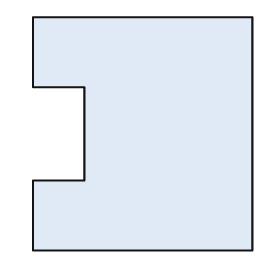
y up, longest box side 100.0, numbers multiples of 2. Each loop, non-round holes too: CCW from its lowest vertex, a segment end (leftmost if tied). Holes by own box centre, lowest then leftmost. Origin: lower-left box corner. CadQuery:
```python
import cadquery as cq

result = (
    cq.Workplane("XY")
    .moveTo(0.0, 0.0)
    .lineTo(94.0, 0.0)
    .lineTo(94.0, 100.0)
    .lineTo(0.0, 100.0)
    .lineTo(0.0, 70.0)
    .lineTo(22.0, 70.0)
    .lineTo(22.0, 30.0)
    .lineTo(0.0, 30.0)
    .close()
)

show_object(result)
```